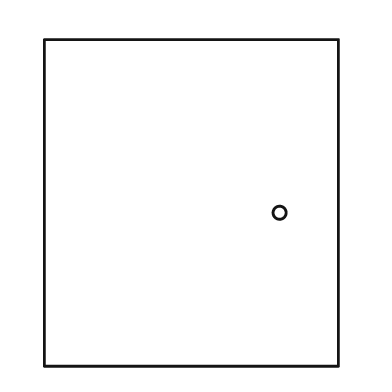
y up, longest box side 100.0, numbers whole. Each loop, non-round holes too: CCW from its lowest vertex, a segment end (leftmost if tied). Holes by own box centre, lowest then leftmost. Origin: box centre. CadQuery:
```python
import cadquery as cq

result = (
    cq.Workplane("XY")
    .moveTo(-45.0, -50.0)
    .lineTo(45.0, -50.0)
    .lineTo(45.0, 50.0)
    .lineTo(-45.0, 50.0)
    .close()
    .moveTo(27.0, -3.0)
    .circle(2.0)
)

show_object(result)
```